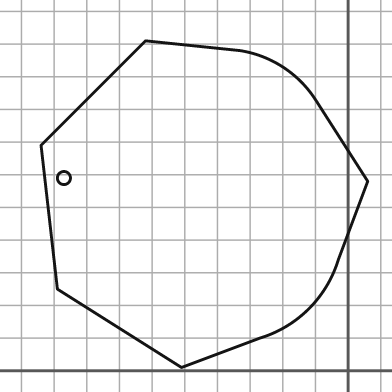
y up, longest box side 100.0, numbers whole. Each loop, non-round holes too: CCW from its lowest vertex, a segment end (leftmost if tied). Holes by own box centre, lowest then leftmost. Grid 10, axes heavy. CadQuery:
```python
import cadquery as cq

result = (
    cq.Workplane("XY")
    .moveTo(-51.0, 1.0)
    .lineTo(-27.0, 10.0)
    .threePointArc((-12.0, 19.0), (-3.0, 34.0))
    .lineTo(6.0, 58.0)
    .lineTo(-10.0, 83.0)
    .threePointArc((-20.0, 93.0), (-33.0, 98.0))
    .lineTo(-62.0, 101.0)
    .lineTo(-94.0, 69.0)
    .lineTo(-89.0, 25.0)
    .close()
    .moveTo(-87.0, 59.0)
    .circle(2.0)
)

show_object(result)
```